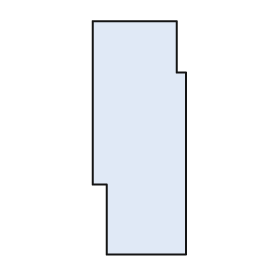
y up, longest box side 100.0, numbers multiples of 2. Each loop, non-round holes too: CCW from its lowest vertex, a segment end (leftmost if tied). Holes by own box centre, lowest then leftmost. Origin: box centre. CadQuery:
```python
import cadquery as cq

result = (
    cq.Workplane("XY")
    .moveTo(-14.0, -50.0)
    .lineTo(20.0, -50.0)
    .lineTo(20.0, 28.0)
    .lineTo(16.0, 28.0)
    .lineTo(16.0, 50.0)
    .lineTo(-20.0, 50.0)
    .lineTo(-20.0, -20.0)
    .lineTo(-14.0, -20.0)
    .close()
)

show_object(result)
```